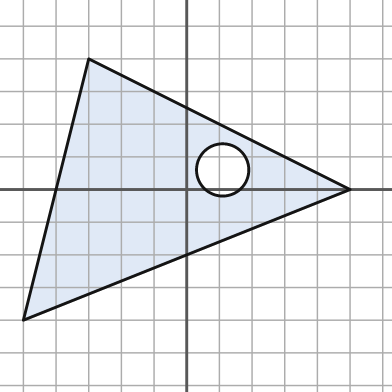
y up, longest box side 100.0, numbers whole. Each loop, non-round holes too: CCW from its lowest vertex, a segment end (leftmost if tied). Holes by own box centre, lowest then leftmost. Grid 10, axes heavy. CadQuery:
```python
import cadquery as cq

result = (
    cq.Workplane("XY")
    .moveTo(-50.0, -40.0)
    .lineTo(50.0, 0.0)
    .lineTo(-30.0, 40.0)
    .close()
    .moveTo(11.0, 6.0)
    .circle(8.0)
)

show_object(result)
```